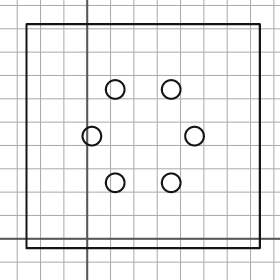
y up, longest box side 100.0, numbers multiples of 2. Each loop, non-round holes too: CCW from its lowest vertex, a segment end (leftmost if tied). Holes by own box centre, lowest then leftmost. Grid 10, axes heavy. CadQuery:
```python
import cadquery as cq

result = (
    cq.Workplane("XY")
    .moveTo(-26.0, -4.0)
    .lineTo(74.0, -4.0)
    .lineTo(74.0, 92.0)
    .lineTo(-26.0, 92.0)
    .close()
    .moveTo(12.0, 24.0)
    .circle(4.0)
    .moveTo(36.0, 24.0)
    .circle(4.0)
    .moveTo(2.0, 44.0)
    .circle(4.0)
    .moveTo(46.0, 44.0)
    .circle(4.0)
    .moveTo(12.0, 64.0)
    .circle(4.0)
    .moveTo(36.0, 64.0)
    .circle(4.0)
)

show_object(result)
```